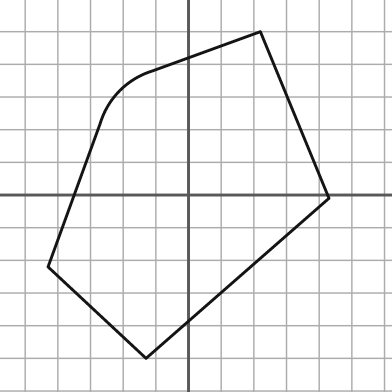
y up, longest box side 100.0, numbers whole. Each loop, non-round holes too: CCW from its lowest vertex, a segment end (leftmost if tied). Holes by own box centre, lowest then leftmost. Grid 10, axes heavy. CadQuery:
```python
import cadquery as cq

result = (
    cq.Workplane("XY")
    .moveTo(-13.0, -50.0)
    .lineTo(43.0, -1.0)
    .lineTo(22.0, 50.0)
    .lineTo(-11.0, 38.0)
    .threePointArc((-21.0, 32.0), (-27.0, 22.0))
    .lineTo(-43.0, -22.0)
    .close()
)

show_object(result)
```